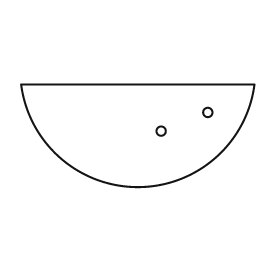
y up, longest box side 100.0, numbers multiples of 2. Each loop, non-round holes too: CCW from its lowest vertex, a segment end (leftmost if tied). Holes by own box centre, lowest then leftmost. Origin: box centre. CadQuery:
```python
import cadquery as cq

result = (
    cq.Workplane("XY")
    .moveTo(-50.0, 22.0)
    .threePointArc((0.0, -22.0), (50.0, 22.0))
    .close()
    .moveTo(10.0, 2.0)
    .circle(2.0)
    .moveTo(30.0, 10.0)
    .circle(2.0)
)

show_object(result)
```